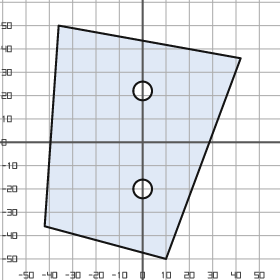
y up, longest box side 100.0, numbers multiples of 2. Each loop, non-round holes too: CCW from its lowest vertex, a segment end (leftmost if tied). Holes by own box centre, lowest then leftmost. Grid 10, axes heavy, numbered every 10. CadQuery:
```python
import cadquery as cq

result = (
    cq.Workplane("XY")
    .moveTo(10.0, -50.0)
    .lineTo(42.0, 36.0)
    .lineTo(-36.0, 50.0)
    .lineTo(-42.0, -36.0)
    .close()
    .moveTo(0.0, -20.0)
    .circle(4.0)
    .moveTo(0.0, 22.0)
    .circle(4.0)
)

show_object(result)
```